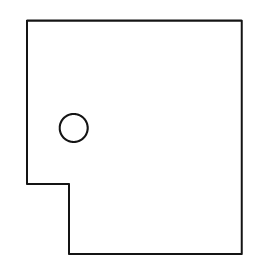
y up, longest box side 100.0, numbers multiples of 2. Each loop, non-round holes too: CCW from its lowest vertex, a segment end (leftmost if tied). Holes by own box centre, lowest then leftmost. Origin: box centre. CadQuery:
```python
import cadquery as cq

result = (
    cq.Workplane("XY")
    .moveTo(-28.0, -50.0)
    .lineTo(46.0, -50.0)
    .lineTo(46.0, 50.0)
    .lineTo(-46.0, 50.0)
    .lineTo(-46.0, -20.0)
    .lineTo(-28.0, -20.0)
    .close()
    .moveTo(-26.0, 4.0)
    .circle(6.0)
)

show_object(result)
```